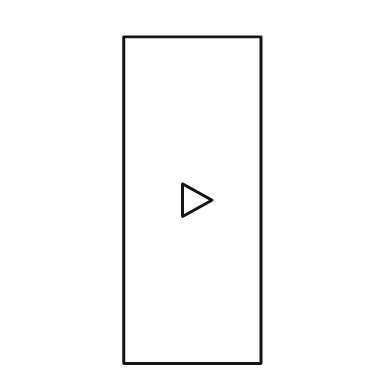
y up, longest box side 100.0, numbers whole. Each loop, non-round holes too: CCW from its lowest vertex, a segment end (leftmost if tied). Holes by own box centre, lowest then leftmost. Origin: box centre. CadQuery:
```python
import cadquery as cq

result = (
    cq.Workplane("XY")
    .moveTo(-21.0, -50.0)
    .lineTo(21.0, -50.0)
    .lineTo(21.0, 50.0)
    .lineTo(-21.0, 50.0)
    .close()
    .moveTo(-3.0, -5.0)
    .lineTo(6.0, 0.0)
    .lineTo(-3.0, 5.0)
    .close()
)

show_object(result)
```